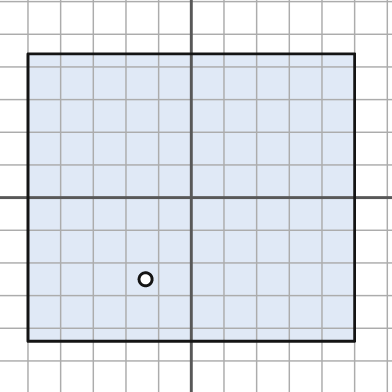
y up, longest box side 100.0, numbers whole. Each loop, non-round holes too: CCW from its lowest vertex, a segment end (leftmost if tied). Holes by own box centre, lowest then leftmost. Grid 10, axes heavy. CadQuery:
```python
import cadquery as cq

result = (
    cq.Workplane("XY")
    .moveTo(-50.0, -44.0)
    .lineTo(50.0, -44.0)
    .lineTo(50.0, 44.0)
    .lineTo(-50.0, 44.0)
    .close()
    .moveTo(-14.0, -25.0)
    .circle(2.0)
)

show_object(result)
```